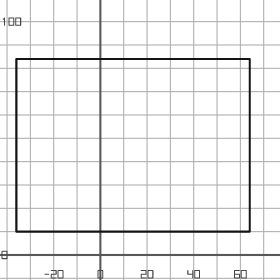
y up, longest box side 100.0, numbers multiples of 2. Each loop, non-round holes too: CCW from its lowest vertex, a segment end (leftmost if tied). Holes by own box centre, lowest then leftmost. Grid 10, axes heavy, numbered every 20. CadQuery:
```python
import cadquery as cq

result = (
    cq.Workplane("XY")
    .moveTo(-36.0, 10.0)
    .lineTo(64.0, 10.0)
    .lineTo(64.0, 84.0)
    .lineTo(-36.0, 84.0)
    .close()
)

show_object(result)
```